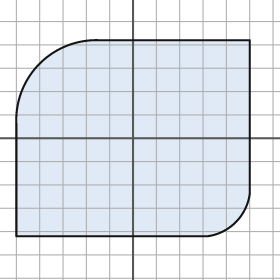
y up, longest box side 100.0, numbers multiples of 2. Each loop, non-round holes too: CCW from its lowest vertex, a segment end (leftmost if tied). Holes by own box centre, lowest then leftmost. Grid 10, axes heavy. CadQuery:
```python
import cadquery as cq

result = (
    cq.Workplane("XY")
    .moveTo(-50.0, -42.0)
    .lineTo(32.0, -42.0)
    .threePointArc((44.0, -36.0), (50.0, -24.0))
    .lineTo(50.0, 42.0)
    .lineTo(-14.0, 42.0)
    .threePointArc((-40.0, 32.0), (-50.0, 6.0))
    .close()
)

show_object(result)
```